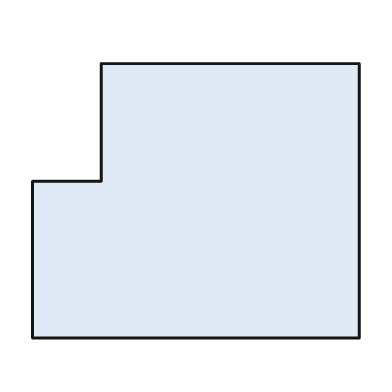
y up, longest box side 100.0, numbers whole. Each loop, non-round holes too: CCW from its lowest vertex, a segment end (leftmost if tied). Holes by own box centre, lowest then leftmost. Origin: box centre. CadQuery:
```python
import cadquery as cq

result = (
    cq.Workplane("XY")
    .moveTo(-50.0, -42.0)
    .lineTo(50.0, -42.0)
    .lineTo(50.0, 42.0)
    .lineTo(-29.0, 42.0)
    .lineTo(-29.0, 6.0)
    .lineTo(-50.0, 6.0)
    .close()
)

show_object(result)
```